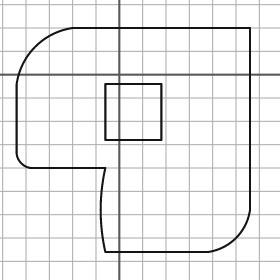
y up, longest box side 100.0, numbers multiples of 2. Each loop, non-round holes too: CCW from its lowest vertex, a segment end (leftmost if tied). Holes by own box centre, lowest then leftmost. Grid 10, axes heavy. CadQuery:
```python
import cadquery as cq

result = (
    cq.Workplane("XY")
    .moveTo(-6.0, -76.0)
    .lineTo(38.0, -76.0)
    .threePointArc((50.0, -70.0), (56.0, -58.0))
    .lineTo(56.0, 20.0)
    .lineTo(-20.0, 20.0)
    .threePointArc((-36.0, 12.0), (-44.0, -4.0))
    .lineTo(-44.0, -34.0)
    .threePointArc((-42.0, -38.0), (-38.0, -40.0))
    .lineTo(-6.0, -40.0)
    .threePointArc((-8.0, -58.0), (-6.0, -76.0))
    .close()
    .moveTo(-6.0, -28.0)
    .lineTo(18.0, -28.0)
    .lineTo(18.0, -4.0)
    .lineTo(-6.0, -4.0)
    .close()
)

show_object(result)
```